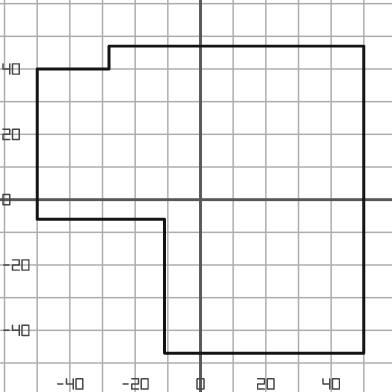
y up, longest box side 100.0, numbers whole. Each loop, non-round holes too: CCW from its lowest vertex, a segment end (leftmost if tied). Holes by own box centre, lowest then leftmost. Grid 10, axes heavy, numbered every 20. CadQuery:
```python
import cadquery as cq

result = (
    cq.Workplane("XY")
    .moveTo(-11.0, -47.0)
    .lineTo(50.0, -47.0)
    .lineTo(50.0, 47.0)
    .lineTo(-28.0, 47.0)
    .lineTo(-28.0, 40.0)
    .lineTo(-50.0, 40.0)
    .lineTo(-50.0, -6.0)
    .lineTo(-11.0, -6.0)
    .close()
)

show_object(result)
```